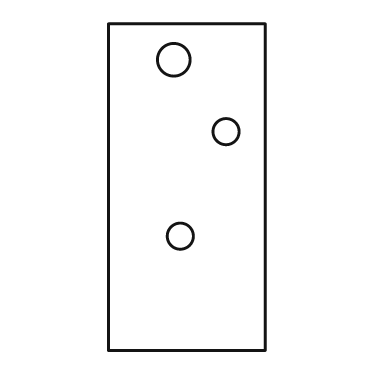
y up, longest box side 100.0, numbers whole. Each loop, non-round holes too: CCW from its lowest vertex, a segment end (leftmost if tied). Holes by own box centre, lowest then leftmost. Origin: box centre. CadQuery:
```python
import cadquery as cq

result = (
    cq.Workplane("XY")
    .moveTo(-24.0, -50.0)
    .lineTo(24.0, -50.0)
    .lineTo(24.0, 50.0)
    .lineTo(-24.0, 50.0)
    .close()
    .moveTo(-2.0, -15.0)
    .circle(4.0)
    .moveTo(12.0, 17.0)
    .circle(4.0)
    .moveTo(-4.0, 39.0)
    .circle(5.0)
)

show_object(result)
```